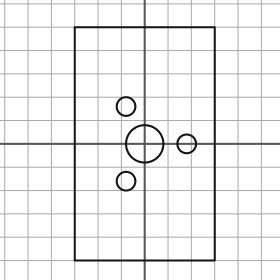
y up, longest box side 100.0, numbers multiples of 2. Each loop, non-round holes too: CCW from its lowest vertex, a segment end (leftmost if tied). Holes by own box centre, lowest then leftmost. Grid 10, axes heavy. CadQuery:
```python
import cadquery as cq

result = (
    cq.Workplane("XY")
    .moveTo(-30.0, -50.0)
    .lineTo(30.0, -50.0)
    .lineTo(30.0, 50.0)
    .lineTo(-30.0, 50.0)
    .close()
    .moveTo(-8.0, -16.0)
    .circle(4.0)
    .moveTo(0.0, 0.0)
    .circle(8.0)
    .moveTo(18.0, 0.0)
    .circle(4.0)
    .moveTo(-8.0, 16.0)
    .circle(4.0)
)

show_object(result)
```